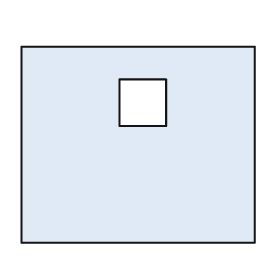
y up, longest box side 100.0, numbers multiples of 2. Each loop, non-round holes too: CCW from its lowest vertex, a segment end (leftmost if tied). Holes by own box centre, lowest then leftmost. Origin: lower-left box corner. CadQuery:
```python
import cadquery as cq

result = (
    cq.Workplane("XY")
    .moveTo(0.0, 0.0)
    .lineTo(100.0, 0.0)
    .lineTo(100.0, 84.0)
    .lineTo(0.0, 84.0)
    .close()
    .moveTo(42.0, 50.0)
    .lineTo(62.0, 50.0)
    .lineTo(62.0, 70.0)
    .lineTo(42.0, 70.0)
    .close()
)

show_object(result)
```